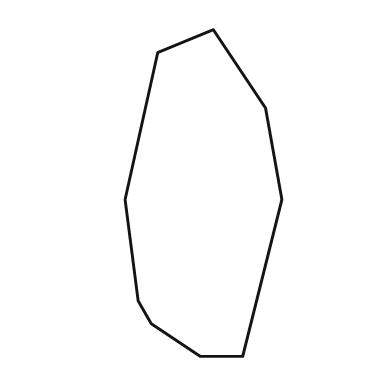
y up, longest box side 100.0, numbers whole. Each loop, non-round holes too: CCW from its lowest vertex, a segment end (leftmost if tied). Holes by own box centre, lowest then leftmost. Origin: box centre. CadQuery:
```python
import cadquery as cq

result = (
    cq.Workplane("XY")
    .moveTo(-1.0, -50.0)
    .lineTo(12.0, -50.0)
    .lineTo(24.0, -2.0)
    .lineTo(19.0, 26.0)
    .lineTo(3.0, 50.0)
    .lineTo(-14.0, 43.0)
    .lineTo(-24.0, -2.0)
    .lineTo(-20.0, -33.0)
    .lineTo(-16.0, -40.0)
    .close()
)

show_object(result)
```